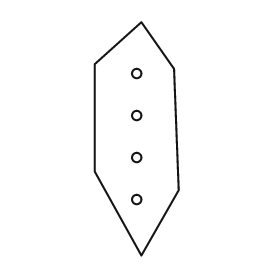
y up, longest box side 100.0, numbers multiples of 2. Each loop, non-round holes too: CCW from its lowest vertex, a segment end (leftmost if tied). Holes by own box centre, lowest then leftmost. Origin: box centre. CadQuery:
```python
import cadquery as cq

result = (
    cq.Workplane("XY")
    .moveTo(2.0, -50.0)
    .lineTo(18.0, -22.0)
    .lineTo(16.0, 30.0)
    .lineTo(2.0, 50.0)
    .lineTo(-18.0, 32.0)
    .lineTo(-18.0, -14.0)
    .close()
    .moveTo(0.0, -26.0)
    .circle(2.0)
    .moveTo(0.0, -8.0)
    .circle(2.0)
    .moveTo(0.0, 10.0)
    .circle(2.0)
    .moveTo(0.0, 28.0)
    .circle(2.0)
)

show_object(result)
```